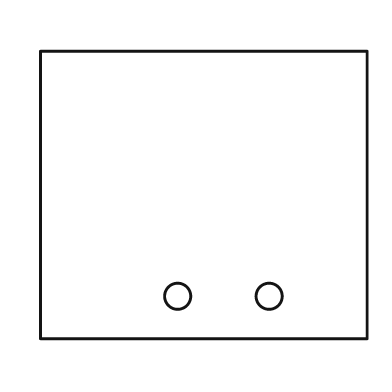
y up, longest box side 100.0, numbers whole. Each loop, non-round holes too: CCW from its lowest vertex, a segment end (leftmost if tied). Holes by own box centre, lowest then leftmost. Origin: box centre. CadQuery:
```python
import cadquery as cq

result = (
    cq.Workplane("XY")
    .moveTo(-50.0, -44.0)
    .lineTo(50.0, -44.0)
    .lineTo(50.0, 44.0)
    .lineTo(-50.0, 44.0)
    .close()
    .moveTo(-8.0, -31.0)
    .circle(4.0)
    .moveTo(20.0, -31.0)
    .circle(4.0)
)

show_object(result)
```